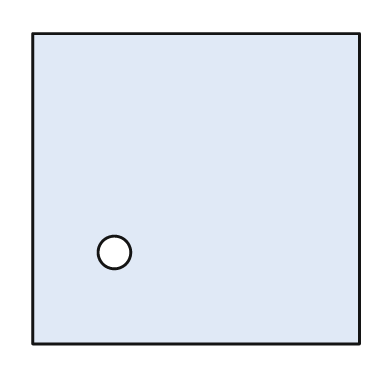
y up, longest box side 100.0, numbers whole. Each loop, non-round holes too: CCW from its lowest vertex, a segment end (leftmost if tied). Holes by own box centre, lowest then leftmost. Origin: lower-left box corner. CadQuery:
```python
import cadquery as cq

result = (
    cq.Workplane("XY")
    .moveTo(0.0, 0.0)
    .lineTo(100.0, 0.0)
    .lineTo(100.0, 95.0)
    .lineTo(0.0, 95.0)
    .close()
    .moveTo(25.0, 28.0)
    .circle(5.0)
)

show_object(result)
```